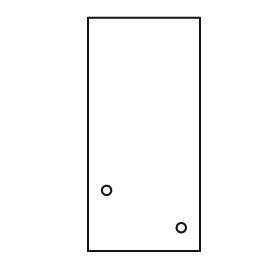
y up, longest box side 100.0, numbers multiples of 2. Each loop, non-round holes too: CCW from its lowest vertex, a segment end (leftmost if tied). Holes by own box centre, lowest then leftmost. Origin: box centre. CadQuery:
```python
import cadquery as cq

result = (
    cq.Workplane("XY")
    .moveTo(-24.0, -50.0)
    .lineTo(24.0, -50.0)
    .lineTo(24.0, 50.0)
    .lineTo(-24.0, 50.0)
    .close()
    .moveTo(16.0, -40.0)
    .circle(2.0)
    .moveTo(-16.0, -24.0)
    .circle(2.0)
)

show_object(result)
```